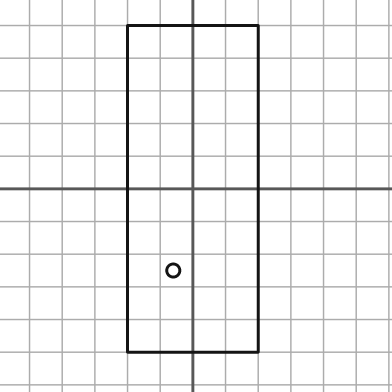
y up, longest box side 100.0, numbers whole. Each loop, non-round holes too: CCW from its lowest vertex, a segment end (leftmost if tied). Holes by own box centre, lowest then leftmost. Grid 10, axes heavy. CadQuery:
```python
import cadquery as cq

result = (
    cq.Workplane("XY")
    .moveTo(-20.0, -50.0)
    .lineTo(20.0, -50.0)
    .lineTo(20.0, 50.0)
    .lineTo(-20.0, 50.0)
    .close()
    .moveTo(-6.0, -25.0)
    .circle(2.0)
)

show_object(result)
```